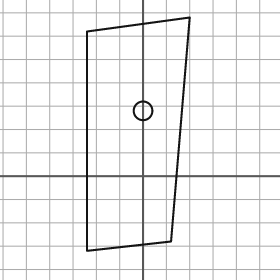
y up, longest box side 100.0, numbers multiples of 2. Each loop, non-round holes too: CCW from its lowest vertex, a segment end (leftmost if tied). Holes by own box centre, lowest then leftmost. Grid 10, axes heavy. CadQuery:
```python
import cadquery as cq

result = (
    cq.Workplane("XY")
    .moveTo(-24.0, -32.0)
    .lineTo(12.0, -28.0)
    .lineTo(20.0, 68.0)
    .lineTo(-24.0, 62.0)
    .close()
    .moveTo(0.0, 28.0)
    .circle(4.0)
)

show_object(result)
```